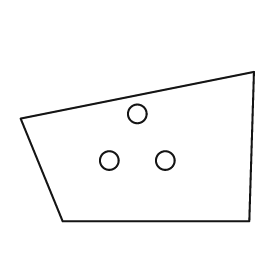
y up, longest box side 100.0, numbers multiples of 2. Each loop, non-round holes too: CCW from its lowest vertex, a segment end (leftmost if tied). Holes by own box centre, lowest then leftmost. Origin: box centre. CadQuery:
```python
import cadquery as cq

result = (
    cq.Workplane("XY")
    .moveTo(-32.0, -32.0)
    .lineTo(48.0, -32.0)
    .lineTo(50.0, 32.0)
    .lineTo(-50.0, 12.0)
    .close()
    .moveTo(-12.0, -6.0)
    .circle(4.0)
    .moveTo(12.0, -6.0)
    .circle(4.0)
    .moveTo(0.0, 14.0)
    .circle(4.0)
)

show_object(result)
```